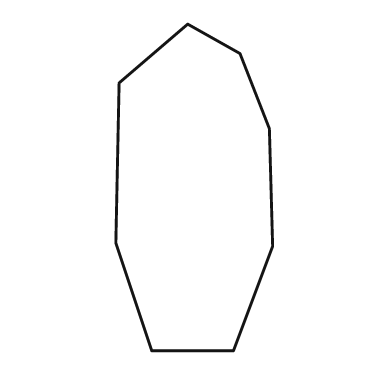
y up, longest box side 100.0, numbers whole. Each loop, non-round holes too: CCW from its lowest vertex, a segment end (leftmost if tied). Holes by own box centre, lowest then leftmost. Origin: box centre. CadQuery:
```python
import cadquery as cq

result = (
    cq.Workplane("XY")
    .moveTo(-13.0, -50.0)
    .lineTo(12.0, -50.0)
    .lineTo(24.0, -18.0)
    .lineTo(23.0, 18.0)
    .lineTo(14.0, 41.0)
    .lineTo(-2.0, 50.0)
    .lineTo(-23.0, 32.0)
    .lineTo(-24.0, -17.0)
    .close()
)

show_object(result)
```